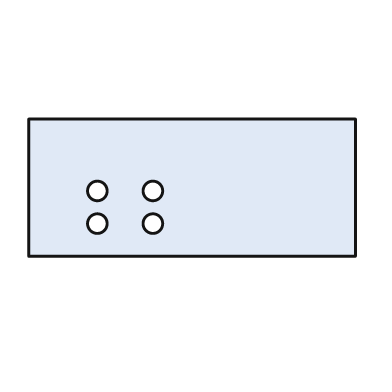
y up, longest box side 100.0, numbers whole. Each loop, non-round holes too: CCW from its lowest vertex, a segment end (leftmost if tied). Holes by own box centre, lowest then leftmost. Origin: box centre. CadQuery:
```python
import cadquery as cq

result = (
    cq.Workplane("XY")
    .moveTo(-50.0, -21.0)
    .lineTo(50.0, -21.0)
    .lineTo(50.0, 21.0)
    .lineTo(-50.0, 21.0)
    .close()
    .moveTo(-29.0, -11.0)
    .circle(3.0)
    .moveTo(-12.0, -11.0)
    .circle(3.0)
    .moveTo(-29.0, -1.0)
    .circle(3.0)
    .moveTo(-12.0, -1.0)
    .circle(3.0)
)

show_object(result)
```